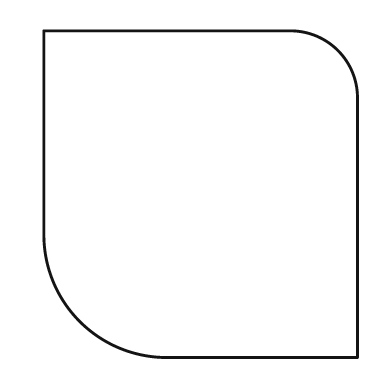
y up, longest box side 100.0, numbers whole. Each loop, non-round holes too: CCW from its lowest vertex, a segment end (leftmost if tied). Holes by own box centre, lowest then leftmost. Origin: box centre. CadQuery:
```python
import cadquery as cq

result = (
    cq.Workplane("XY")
    .moveTo(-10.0, -50.0)
    .lineTo(48.0, -50.0)
    .lineTo(48.0, 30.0)
    .threePointArc((42.0, 44.0), (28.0, 50.0))
    .lineTo(-48.0, 50.0)
    .lineTo(-48.0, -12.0)
    .threePointArc((-37.0, -39.0), (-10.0, -50.0))
    .close()
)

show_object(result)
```